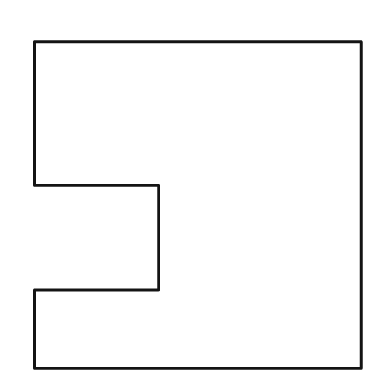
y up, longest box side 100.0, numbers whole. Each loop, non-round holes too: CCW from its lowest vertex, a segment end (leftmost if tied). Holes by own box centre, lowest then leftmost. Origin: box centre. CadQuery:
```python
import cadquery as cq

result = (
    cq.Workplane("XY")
    .moveTo(-50.0, -50.0)
    .lineTo(50.0, -50.0)
    .lineTo(50.0, 50.0)
    .lineTo(-50.0, 50.0)
    .lineTo(-50.0, 6.0)
    .lineTo(-12.0, 6.0)
    .lineTo(-12.0, -26.0)
    .lineTo(-50.0, -26.0)
    .close()
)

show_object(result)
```